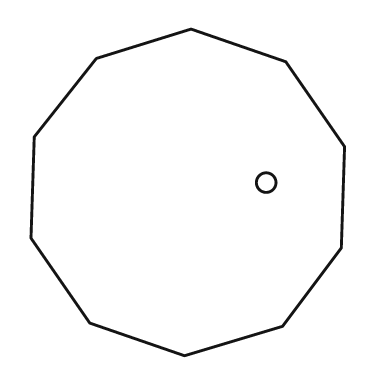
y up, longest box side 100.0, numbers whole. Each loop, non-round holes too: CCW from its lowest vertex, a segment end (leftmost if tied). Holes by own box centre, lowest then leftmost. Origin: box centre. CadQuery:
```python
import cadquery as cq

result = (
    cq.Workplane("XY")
    .moveTo(-1.0, -50.0)
    .lineTo(29.0, -41.0)
    .lineTo(47.0, -17.0)
    .lineTo(48.0, 14.0)
    .lineTo(30.0, 40.0)
    .lineTo(1.0, 50.0)
    .lineTo(-28.0, 41.0)
    .lineTo(-47.0, 17.0)
    .lineTo(-48.0, -14.0)
    .lineTo(-30.0, -40.0)
    .close()
    .moveTo(24.0, 3.0)
    .circle(3.0)
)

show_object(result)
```